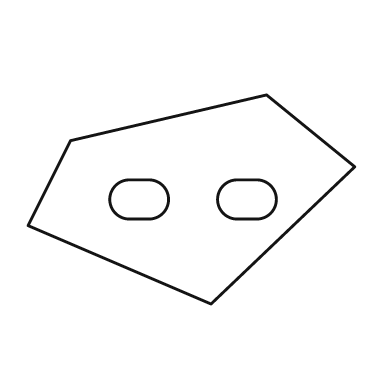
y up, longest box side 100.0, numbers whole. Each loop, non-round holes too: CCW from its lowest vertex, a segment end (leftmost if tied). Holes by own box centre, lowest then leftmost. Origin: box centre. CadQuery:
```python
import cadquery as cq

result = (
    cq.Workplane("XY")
    .moveTo(6.0, -32.0)
    .lineTo(50.0, 10.0)
    .lineTo(23.0, 32.0)
    .lineTo(-37.0, 18.0)
    .lineTo(-50.0, -8.0)
    .close()
    .moveTo(-19.0, -6.0)
    .lineTo(-13.0, -6.0)
    .threePointArc((-7.0, 0.0), (-13.0, 6.0))
    .lineTo(-19.0, 6.0)
    .threePointArc((-25.0, 0.0), (-19.0, -6.0))
    .close()
    .moveTo(14.0, -6.0)
    .lineTo(20.0, -6.0)
    .threePointArc((26.0, 0.0), (20.0, 6.0))
    .lineTo(14.0, 6.0)
    .threePointArc((8.0, 0.0), (14.0, -6.0))
    .close()
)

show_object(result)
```